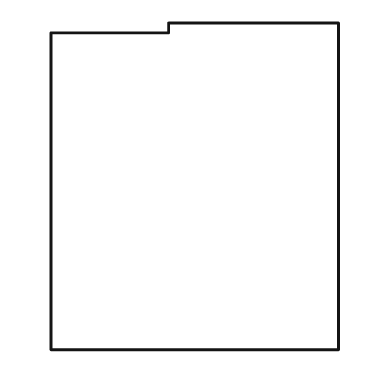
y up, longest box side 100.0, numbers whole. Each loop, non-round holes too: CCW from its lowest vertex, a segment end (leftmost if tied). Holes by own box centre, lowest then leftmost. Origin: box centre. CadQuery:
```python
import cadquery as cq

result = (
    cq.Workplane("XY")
    .moveTo(-44.0, -50.0)
    .lineTo(44.0, -50.0)
    .lineTo(44.0, 50.0)
    .lineTo(-8.0, 50.0)
    .lineTo(-8.0, 47.0)
    .lineTo(-44.0, 47.0)
    .close()
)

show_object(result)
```